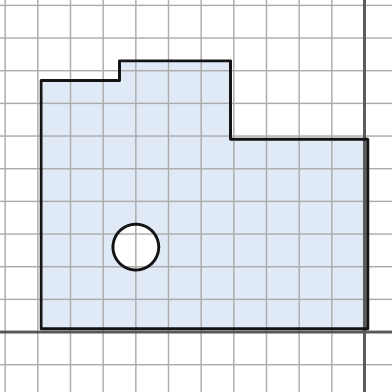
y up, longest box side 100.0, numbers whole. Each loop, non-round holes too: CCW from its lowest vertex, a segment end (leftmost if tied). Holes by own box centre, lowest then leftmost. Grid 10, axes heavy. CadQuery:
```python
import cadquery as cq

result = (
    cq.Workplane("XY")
    .moveTo(-99.0, 1.0)
    .lineTo(1.0, 1.0)
    .lineTo(1.0, 59.0)
    .lineTo(-41.0, 59.0)
    .lineTo(-41.0, 83.0)
    .lineTo(-75.0, 83.0)
    .lineTo(-75.0, 77.0)
    .lineTo(-99.0, 77.0)
    .close()
    .moveTo(-70.0, 26.0)
    .circle(7.0)
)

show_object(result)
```